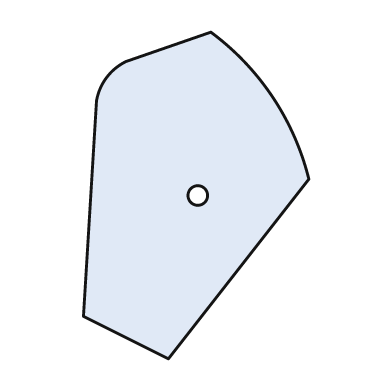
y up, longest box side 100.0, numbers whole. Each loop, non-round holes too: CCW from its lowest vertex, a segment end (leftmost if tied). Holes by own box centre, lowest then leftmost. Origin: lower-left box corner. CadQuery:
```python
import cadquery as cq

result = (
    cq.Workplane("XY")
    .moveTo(26.0, 0.0)
    .lineTo(69.0, 55.0)
    .threePointArc((58.0, 80.0), (39.0, 100.0))
    .lineTo(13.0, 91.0)
    .threePointArc((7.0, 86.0), (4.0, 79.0))
    .lineTo(0.0, 13.0)
    .close()
    .moveTo(35.0, 50.0)
    .circle(3.0)
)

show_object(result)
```